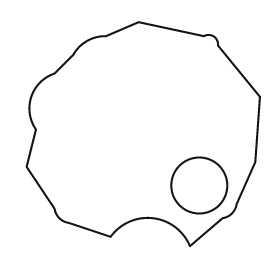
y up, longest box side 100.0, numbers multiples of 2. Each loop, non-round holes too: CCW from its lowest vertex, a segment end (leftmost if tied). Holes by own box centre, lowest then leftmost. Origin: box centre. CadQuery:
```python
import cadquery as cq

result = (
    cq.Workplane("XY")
    .moveTo(20.0, -48.0)
    .lineTo(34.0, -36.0)
    .threePointArc((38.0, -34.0), (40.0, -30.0))
    .lineTo(48.0, -12.0)
    .lineTo(50.0, 16.0)
    .lineTo(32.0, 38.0)
    .threePointArc((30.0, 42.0), (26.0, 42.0))
    .lineTo(-2.0, 48.0)
    .lineTo(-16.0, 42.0)
    .threePointArc((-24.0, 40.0), (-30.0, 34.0))
    .lineTo(-38.0, 26.0)
    .threePointArc((-48.0, 16.0), (-46.0, 2.0))
    .lineTo(-50.0, -14.0)
    .lineTo(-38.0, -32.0)
    .threePointArc((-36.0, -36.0), (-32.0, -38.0))
    .lineTo(-14.0, -44.0)
    .threePointArc((4.0, -36.0), (20.0, -48.0))
    .close()
    .moveTo(24.0, -22.0)
    .circle(12.0)
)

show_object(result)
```